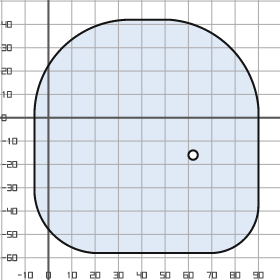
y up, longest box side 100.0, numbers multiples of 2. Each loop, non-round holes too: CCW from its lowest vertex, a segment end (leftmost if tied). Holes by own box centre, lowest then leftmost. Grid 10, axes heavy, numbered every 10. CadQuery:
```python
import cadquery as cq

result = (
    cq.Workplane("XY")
    .moveTo(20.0, -58.0)
    .lineTo(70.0, -58.0)
    .threePointArc((84.0, -52.0), (90.0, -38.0))
    .lineTo(90.0, 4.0)
    .threePointArc((78.0, 30.0), (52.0, 42.0))
    .lineTo(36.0, 42.0)
    .threePointArc((6.0, 30.0), (-6.0, 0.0))
    .lineTo(-6.0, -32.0)
    .threePointArc((2.0, -50.0), (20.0, -58.0))
    .close()
    .moveTo(62.0, -16.0)
    .circle(2.0)
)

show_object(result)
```